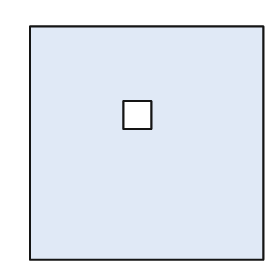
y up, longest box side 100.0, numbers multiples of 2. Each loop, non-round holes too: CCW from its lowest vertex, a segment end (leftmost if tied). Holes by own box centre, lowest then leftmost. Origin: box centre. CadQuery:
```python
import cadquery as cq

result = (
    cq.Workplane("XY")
    .moveTo(-50.0, -50.0)
    .lineTo(50.0, -50.0)
    .lineTo(50.0, 50.0)
    .lineTo(-50.0, 50.0)
    .close()
    .moveTo(-10.0, 6.0)
    .lineTo(2.0, 6.0)
    .lineTo(2.0, 18.0)
    .lineTo(-10.0, 18.0)
    .close()
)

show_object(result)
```